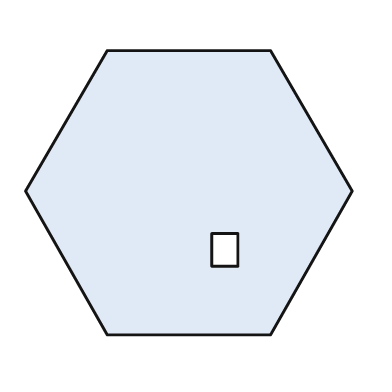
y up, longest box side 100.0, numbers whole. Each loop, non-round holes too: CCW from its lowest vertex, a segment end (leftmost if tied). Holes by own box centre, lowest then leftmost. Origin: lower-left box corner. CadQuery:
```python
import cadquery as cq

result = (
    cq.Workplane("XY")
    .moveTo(25.0, 0.0)
    .lineTo(75.0, 0.0)
    .lineTo(100.0, 44.0)
    .lineTo(75.0, 87.0)
    .lineTo(25.0, 87.0)
    .lineTo(0.0, 44.0)
    .close()
    .moveTo(57.0, 21.0)
    .lineTo(65.0, 21.0)
    .lineTo(65.0, 31.0)
    .lineTo(57.0, 31.0)
    .close()
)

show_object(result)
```